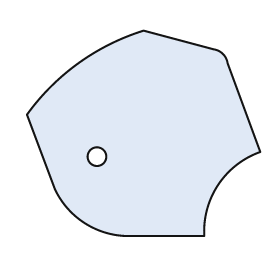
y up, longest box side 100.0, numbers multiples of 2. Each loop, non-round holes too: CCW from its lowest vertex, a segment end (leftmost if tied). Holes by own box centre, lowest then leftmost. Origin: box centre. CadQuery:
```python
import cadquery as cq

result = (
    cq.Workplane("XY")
    .moveTo(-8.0, -44.0)
    .lineTo(26.0, -44.0)
    .threePointArc((32.0, -22.0), (50.0, -8.0))
    .lineTo(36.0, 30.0)
    .threePointArc((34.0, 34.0), (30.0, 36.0))
    .lineTo(0.0, 44.0)
    .threePointArc((-28.0, 30.0), (-50.0, 8.0))
    .lineTo(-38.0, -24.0)
    .threePointArc((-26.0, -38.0), (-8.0, -44.0))
    .close()
    .moveTo(-20.0, -10.0)
    .circle(4.0)
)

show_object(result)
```